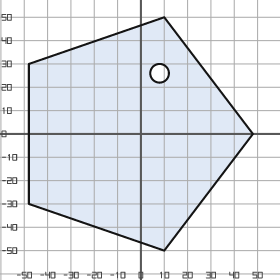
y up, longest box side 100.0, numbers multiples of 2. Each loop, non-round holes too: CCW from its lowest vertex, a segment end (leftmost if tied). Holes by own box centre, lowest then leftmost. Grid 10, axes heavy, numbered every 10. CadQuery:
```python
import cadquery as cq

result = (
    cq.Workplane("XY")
    .moveTo(10.0, -50.0)
    .lineTo(48.0, 0.0)
    .lineTo(10.0, 50.0)
    .lineTo(-48.0, 30.0)
    .lineTo(-48.0, -30.0)
    .close()
    .moveTo(8.0, 26.0)
    .circle(4.0)
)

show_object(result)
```